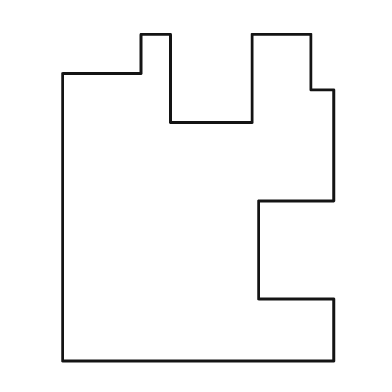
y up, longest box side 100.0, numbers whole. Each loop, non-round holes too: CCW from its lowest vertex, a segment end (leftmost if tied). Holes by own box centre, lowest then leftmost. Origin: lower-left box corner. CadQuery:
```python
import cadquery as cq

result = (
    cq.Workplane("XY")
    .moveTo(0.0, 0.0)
    .lineTo(83.0, 0.0)
    .lineTo(83.0, 19.0)
    .lineTo(60.0, 19.0)
    .lineTo(60.0, 49.0)
    .lineTo(83.0, 49.0)
    .lineTo(83.0, 83.0)
    .lineTo(76.0, 83.0)
    .lineTo(76.0, 100.0)
    .lineTo(58.0, 100.0)
    .lineTo(58.0, 73.0)
    .lineTo(33.0, 73.0)
    .lineTo(33.0, 100.0)
    .lineTo(24.0, 100.0)
    .lineTo(24.0, 88.0)
    .lineTo(0.0, 88.0)
    .close()
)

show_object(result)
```